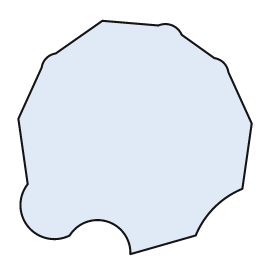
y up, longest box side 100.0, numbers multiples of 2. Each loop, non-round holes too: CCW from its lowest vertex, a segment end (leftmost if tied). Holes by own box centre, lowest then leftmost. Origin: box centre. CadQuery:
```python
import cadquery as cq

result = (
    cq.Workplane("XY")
    .moveTo(-2.0, -50.0)
    .lineTo(26.0, -42.0)
    .threePointArc((34.0, -30.0), (46.0, -22.0))
    .lineTo(50.0, 6.0)
    .lineTo(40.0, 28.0)
    .threePointArc((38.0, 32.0), (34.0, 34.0))
    .lineTo(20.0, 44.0)
    .threePointArc((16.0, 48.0), (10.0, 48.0))
    .lineTo(-14.0, 50.0)
    .lineTo(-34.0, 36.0)
    .threePointArc((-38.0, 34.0), (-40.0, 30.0))
    .lineTo(-50.0, 8.0)
    .lineTo(-46.0, -20.0)
    .threePointArc((-46.0, -38.0), (-28.0, -42.0))
    .threePointArc((-12.0, -36.0), (-2.0, -50.0))
    .close()
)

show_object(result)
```